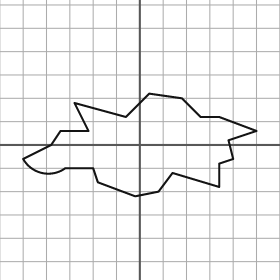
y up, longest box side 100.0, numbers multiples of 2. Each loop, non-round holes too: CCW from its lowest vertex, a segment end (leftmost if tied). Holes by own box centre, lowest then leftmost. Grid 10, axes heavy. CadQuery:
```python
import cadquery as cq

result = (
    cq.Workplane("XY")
    .moveTo(-2.0, -22.0)
    .lineTo(8.0, -20.0)
    .lineTo(14.0, -12.0)
    .lineTo(34.0, -18.0)
    .lineTo(34.0, -8.0)
    .lineTo(40.0, -6.0)
    .lineTo(38.0, 2.0)
    .lineTo(50.0, 6.0)
    .lineTo(34.0, 12.0)
    .lineTo(26.0, 12.0)
    .lineTo(18.0, 20.0)
    .lineTo(4.0, 22.0)
    .lineTo(-6.0, 12.0)
    .lineTo(-28.0, 18.0)
    .lineTo(-22.0, 6.0)
    .lineTo(-34.0, 6.0)
    .lineTo(-38.0, 0.0)
    .lineTo(-50.0, -6.0)
    .threePointArc((-42.0, -12.0), (-32.0, -10.0))
    .lineTo(-20.0, -10.0)
    .lineTo(-18.0, -16.0)
    .close()
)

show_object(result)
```